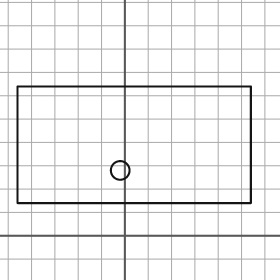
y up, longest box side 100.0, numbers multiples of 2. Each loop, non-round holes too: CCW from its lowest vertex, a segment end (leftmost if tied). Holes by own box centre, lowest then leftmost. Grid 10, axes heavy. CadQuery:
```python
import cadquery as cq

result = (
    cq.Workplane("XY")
    .moveTo(-46.0, 14.0)
    .lineTo(54.0, 14.0)
    .lineTo(54.0, 64.0)
    .lineTo(-46.0, 64.0)
    .close()
    .moveTo(-2.0, 28.0)
    .circle(4.0)
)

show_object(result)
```